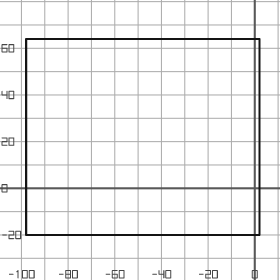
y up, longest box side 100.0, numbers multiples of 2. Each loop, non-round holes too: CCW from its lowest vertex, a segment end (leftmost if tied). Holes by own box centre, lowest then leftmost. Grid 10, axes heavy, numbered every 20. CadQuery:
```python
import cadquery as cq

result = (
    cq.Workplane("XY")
    .moveTo(-98.0, -20.0)
    .lineTo(2.0, -20.0)
    .lineTo(2.0, 64.0)
    .lineTo(-98.0, 64.0)
    .close()
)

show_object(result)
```